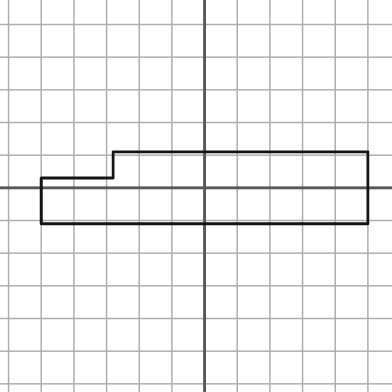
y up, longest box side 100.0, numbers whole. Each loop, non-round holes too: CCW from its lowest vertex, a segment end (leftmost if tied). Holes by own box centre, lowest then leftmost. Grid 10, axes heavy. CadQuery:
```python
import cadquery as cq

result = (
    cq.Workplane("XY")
    .moveTo(-50.0, -11.0)
    .lineTo(50.0, -11.0)
    .lineTo(50.0, 11.0)
    .lineTo(-28.0, 11.0)
    .lineTo(-28.0, 3.0)
    .lineTo(-50.0, 3.0)
    .close()
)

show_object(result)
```